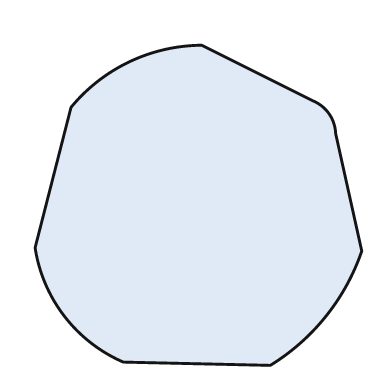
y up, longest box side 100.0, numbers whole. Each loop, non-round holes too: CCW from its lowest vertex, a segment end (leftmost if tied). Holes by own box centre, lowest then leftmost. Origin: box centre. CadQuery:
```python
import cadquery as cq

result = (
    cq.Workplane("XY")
    .moveTo(22.0, -49.0)
    .threePointArc((39.0, -34.0), (50.0, -14.0))
    .lineTo(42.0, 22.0)
    .threePointArc((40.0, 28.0), (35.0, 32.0))
    .lineTo(1.0, 49.0)
    .threePointArc((-21.0, 44.0), (-39.0, 30.0))
    .lineTo(-50.0, -13.0)
    .threePointArc((-41.0, -34.0), (-23.0, -48.0))
    .close()
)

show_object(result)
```